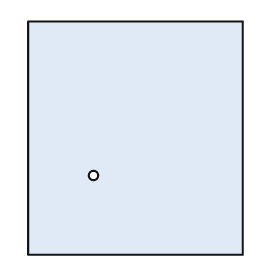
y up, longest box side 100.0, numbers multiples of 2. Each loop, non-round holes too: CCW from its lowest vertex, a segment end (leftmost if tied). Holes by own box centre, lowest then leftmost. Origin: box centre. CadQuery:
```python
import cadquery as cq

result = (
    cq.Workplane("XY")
    .moveTo(-46.0, -50.0)
    .lineTo(46.0, -50.0)
    .lineTo(46.0, 50.0)
    .lineTo(-46.0, 50.0)
    .close()
    .moveTo(-18.0, -16.0)
    .circle(2.0)
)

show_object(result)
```